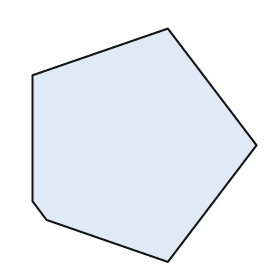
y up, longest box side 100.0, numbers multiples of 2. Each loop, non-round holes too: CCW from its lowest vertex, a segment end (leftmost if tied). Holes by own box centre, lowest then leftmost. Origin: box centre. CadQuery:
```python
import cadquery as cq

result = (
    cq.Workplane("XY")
    .moveTo(10.0, -50.0)
    .lineTo(48.0, 0.0)
    .lineTo(10.0, 50.0)
    .lineTo(-48.0, 30.0)
    .lineTo(-48.0, -24.0)
    .lineTo(-42.0, -32.0)
    .close()
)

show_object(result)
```